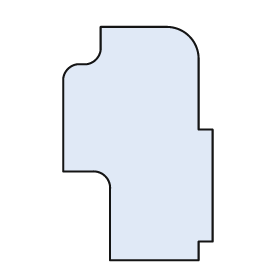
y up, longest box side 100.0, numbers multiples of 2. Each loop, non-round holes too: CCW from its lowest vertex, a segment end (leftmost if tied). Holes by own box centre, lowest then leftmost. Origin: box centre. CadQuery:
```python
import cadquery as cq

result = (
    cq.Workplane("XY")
    .moveTo(-12.0, -50.0)
    .lineTo(26.0, -50.0)
    .lineTo(26.0, -42.0)
    .lineTo(32.0, -42.0)
    .lineTo(32.0, 6.0)
    .lineTo(26.0, 6.0)
    .lineTo(26.0, 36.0)
    .threePointArc((22.0, 46.0), (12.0, 50.0))
    .lineTo(-16.0, 50.0)
    .lineTo(-16.0, 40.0)
    .threePointArc((-18.0, 36.0), (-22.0, 34.0))
    .lineTo(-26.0, 34.0)
    .threePointArc((-30.0, 32.0), (-32.0, 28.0))
    .lineTo(-32.0, -12.0)
    .lineTo(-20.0, -12.0)
    .threePointArc((-14.0, -14.0), (-12.0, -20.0))
    .close()
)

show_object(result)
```